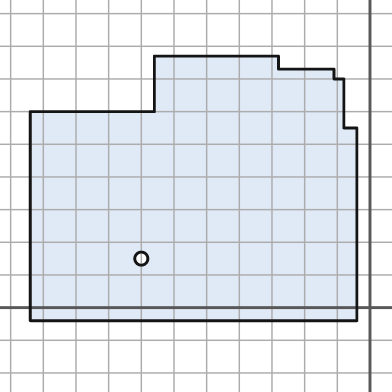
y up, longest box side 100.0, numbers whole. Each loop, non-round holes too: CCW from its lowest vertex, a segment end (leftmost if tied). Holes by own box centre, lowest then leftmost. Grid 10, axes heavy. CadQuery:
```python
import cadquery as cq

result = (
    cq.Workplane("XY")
    .moveTo(-104.0, -4.0)
    .lineTo(-4.0, -4.0)
    .lineTo(-4.0, 55.0)
    .lineTo(-8.0, 55.0)
    .lineTo(-8.0, 70.0)
    .lineTo(-11.0, 70.0)
    .lineTo(-11.0, 73.0)
    .lineTo(-28.0, 73.0)
    .lineTo(-28.0, 77.0)
    .lineTo(-66.0, 77.0)
    .lineTo(-66.0, 60.0)
    .lineTo(-104.0, 60.0)
    .close()
    .moveTo(-70.0, 15.0)
    .circle(2.0)
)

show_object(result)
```